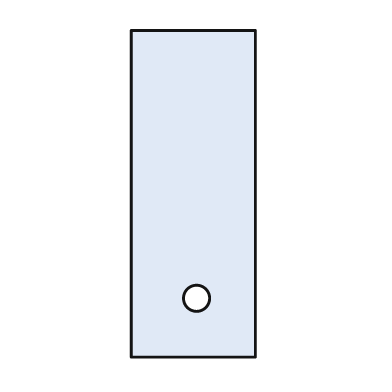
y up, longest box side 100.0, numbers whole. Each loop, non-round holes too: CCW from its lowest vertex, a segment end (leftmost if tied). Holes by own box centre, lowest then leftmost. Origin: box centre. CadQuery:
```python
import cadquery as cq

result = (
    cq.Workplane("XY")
    .moveTo(-19.0, -50.0)
    .lineTo(19.0, -50.0)
    .lineTo(19.0, 50.0)
    .lineTo(-19.0, 50.0)
    .close()
    .moveTo(1.0, -32.0)
    .circle(4.0)
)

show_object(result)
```